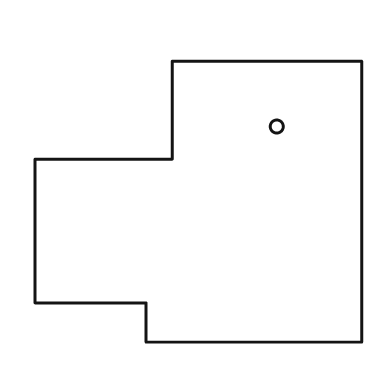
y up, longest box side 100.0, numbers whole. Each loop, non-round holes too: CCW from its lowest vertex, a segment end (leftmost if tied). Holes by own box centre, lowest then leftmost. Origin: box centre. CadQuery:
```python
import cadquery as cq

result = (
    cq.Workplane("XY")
    .moveTo(-16.0, -43.0)
    .lineTo(50.0, -43.0)
    .lineTo(50.0, 43.0)
    .lineTo(-8.0, 43.0)
    .lineTo(-8.0, 13.0)
    .lineTo(-50.0, 13.0)
    .lineTo(-50.0, -31.0)
    .lineTo(-16.0, -31.0)
    .close()
    .moveTo(24.0, 23.0)
    .circle(2.0)
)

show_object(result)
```